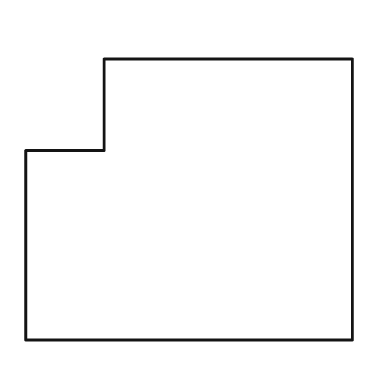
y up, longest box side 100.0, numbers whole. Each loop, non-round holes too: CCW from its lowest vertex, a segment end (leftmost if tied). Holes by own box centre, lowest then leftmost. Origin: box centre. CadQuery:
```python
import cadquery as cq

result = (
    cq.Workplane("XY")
    .moveTo(-50.0, -43.0)
    .lineTo(50.0, -43.0)
    .lineTo(50.0, 43.0)
    .lineTo(-26.0, 43.0)
    .lineTo(-26.0, 15.0)
    .lineTo(-50.0, 15.0)
    .close()
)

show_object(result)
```